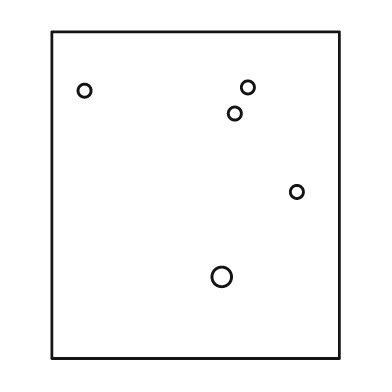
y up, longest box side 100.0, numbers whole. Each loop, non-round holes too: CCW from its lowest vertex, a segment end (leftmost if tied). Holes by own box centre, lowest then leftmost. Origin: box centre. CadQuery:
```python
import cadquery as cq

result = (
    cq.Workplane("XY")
    .moveTo(-44.0, -50.0)
    .lineTo(44.0, -50.0)
    .lineTo(44.0, 50.0)
    .lineTo(-44.0, 50.0)
    .close()
    .moveTo(8.0, -25.0)
    .circle(3.0)
    .moveTo(31.0, 1.0)
    .circle(2.0)
    .moveTo(12.0, 25.0)
    .circle(2.0)
    .moveTo(-34.0, 32.0)
    .circle(2.0)
    .moveTo(16.0, 33.0)
    .circle(2.0)
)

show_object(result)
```